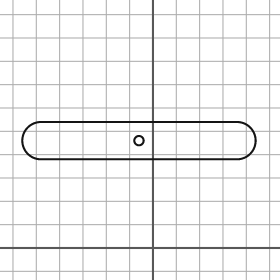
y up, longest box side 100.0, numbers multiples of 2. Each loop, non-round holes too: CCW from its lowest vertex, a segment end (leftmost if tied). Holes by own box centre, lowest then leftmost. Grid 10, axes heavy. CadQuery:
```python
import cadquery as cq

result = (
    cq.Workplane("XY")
    .moveTo(-48.0, 38.0)
    .lineTo(36.0, 38.0)
    .threePointArc((44.0, 46.0), (36.0, 54.0))
    .lineTo(-48.0, 54.0)
    .threePointArc((-56.0, 46.0), (-48.0, 38.0))
    .close()
    .moveTo(-6.0, 46.0)
    .circle(2.0)
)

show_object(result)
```